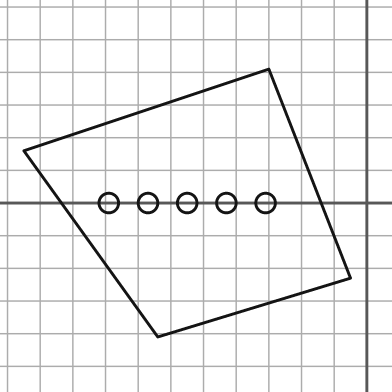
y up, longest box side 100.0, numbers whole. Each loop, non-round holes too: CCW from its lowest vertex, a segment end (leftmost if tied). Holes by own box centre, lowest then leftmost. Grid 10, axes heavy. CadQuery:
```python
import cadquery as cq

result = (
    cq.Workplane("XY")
    .moveTo(-64.0, -41.0)
    .lineTo(-5.0, -23.0)
    .lineTo(-30.0, 41.0)
    .lineTo(-105.0, 16.0)
    .close()
    .moveTo(-79.0, 0.0)
    .circle(3.0)
    .moveTo(-67.0, 0.0)
    .circle(3.0)
    .moveTo(-55.0, 0.0)
    .circle(3.0)
    .moveTo(-43.0, 0.0)
    .circle(3.0)
    .moveTo(-31.0, 0.0)
    .circle(3.0)
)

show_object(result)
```